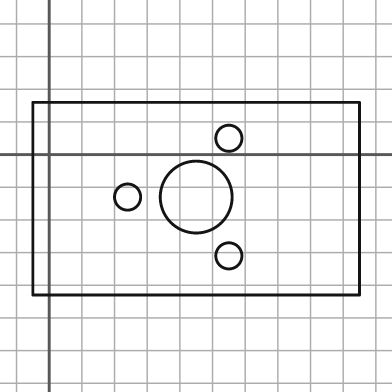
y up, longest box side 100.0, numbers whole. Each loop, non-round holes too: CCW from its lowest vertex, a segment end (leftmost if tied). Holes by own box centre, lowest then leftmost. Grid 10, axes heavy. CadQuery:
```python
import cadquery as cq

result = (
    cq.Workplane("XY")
    .moveTo(-5.0, -43.0)
    .lineTo(95.0, -43.0)
    .lineTo(95.0, 16.0)
    .lineTo(-5.0, 16.0)
    .close()
    .moveTo(55.0, -31.0)
    .circle(4.0)
    .moveTo(24.0, -13.0)
    .circle(4.0)
    .moveTo(45.0, -13.0)
    .circle(11.0)
    .moveTo(55.0, 5.0)
    .circle(4.0)
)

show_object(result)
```